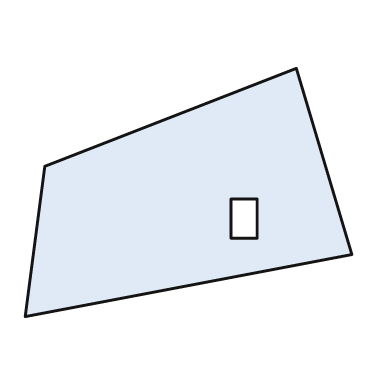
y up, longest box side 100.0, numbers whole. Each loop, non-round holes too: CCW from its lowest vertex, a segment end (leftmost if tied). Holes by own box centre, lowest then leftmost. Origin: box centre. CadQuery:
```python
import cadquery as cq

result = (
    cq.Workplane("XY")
    .moveTo(-50.0, -38.0)
    .lineTo(50.0, -19.0)
    .lineTo(33.0, 38.0)
    .lineTo(-44.0, 8.0)
    .close()
    .moveTo(13.0, -14.0)
    .lineTo(21.0, -14.0)
    .lineTo(21.0, -2.0)
    .lineTo(13.0, -2.0)
    .close()
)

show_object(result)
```